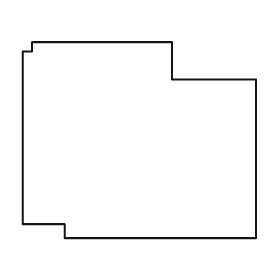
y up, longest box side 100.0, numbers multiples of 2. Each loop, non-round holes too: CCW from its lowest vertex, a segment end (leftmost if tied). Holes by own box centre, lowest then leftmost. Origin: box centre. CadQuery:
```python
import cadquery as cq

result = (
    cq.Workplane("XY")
    .moveTo(-32.0, -42.0)
    .lineTo(50.0, -42.0)
    .lineTo(50.0, 26.0)
    .lineTo(14.0, 26.0)
    .lineTo(14.0, 42.0)
    .lineTo(-46.0, 42.0)
    .lineTo(-46.0, 38.0)
    .lineTo(-50.0, 38.0)
    .lineTo(-50.0, -36.0)
    .lineTo(-32.0, -36.0)
    .close()
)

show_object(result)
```